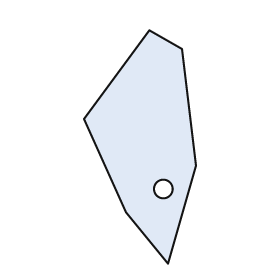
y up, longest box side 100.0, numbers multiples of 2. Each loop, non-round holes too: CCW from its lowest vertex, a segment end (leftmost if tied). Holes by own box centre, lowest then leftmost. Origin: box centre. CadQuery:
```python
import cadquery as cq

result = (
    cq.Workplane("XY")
    .moveTo(12.0, -50.0)
    .lineTo(24.0, -8.0)
    .lineTo(18.0, 42.0)
    .lineTo(4.0, 50.0)
    .lineTo(-24.0, 12.0)
    .lineTo(-6.0, -28.0)
    .close()
    .moveTo(10.0, -18.0)
    .circle(4.0)
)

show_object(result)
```